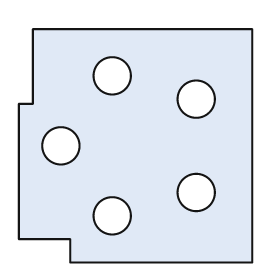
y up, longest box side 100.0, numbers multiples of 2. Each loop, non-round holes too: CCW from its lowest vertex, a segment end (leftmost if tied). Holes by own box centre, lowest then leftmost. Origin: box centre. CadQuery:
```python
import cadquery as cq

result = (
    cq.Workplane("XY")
    .moveTo(-28.0, -50.0)
    .lineTo(50.0, -50.0)
    .lineTo(50.0, 50.0)
    .lineTo(-44.0, 50.0)
    .lineTo(-44.0, 18.0)
    .lineTo(-50.0, 18.0)
    .lineTo(-50.0, -40.0)
    .lineTo(-28.0, -40.0)
    .close()
    .moveTo(-10.0, -30.0)
    .circle(8.0)
    .moveTo(26.0, -20.0)
    .circle(8.0)
    .moveTo(-32.0, 0.0)
    .circle(8.0)
    .moveTo(26.0, 20.0)
    .circle(8.0)
    .moveTo(-10.0, 30.0)
    .circle(8.0)
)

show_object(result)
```